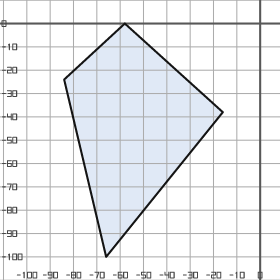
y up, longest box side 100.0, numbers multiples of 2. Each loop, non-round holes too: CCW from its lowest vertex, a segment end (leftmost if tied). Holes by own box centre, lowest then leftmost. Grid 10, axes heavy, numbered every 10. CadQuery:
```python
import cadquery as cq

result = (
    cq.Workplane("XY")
    .moveTo(-66.0, -100.0)
    .lineTo(-16.0, -38.0)
    .lineTo(-58.0, 0.0)
    .lineTo(-84.0, -24.0)
    .close()
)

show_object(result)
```